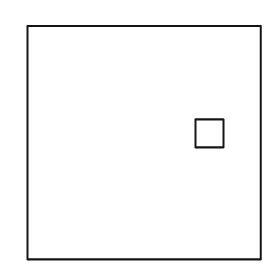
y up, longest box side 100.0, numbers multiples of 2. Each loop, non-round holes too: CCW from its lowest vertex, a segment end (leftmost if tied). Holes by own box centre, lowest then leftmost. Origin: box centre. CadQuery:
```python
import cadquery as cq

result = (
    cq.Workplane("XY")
    .moveTo(-50.0, -50.0)
    .lineTo(50.0, -50.0)
    .lineTo(50.0, 50.0)
    .lineTo(-50.0, 50.0)
    .close()
    .moveTo(22.0, -2.0)
    .lineTo(34.0, -2.0)
    .lineTo(34.0, 10.0)
    .lineTo(22.0, 10.0)
    .close()
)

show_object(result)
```